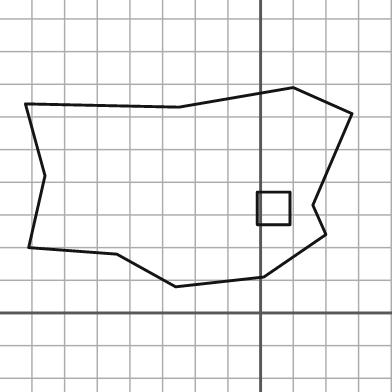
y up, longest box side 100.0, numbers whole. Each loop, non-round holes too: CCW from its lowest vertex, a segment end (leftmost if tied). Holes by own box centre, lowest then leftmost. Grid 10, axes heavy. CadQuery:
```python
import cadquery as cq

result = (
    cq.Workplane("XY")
    .moveTo(-26.0, 8.0)
    .lineTo(1.0, 11.0)
    .lineTo(20.0, 24.0)
    .lineTo(16.0, 33.0)
    .lineTo(28.0, 61.0)
    .lineTo(10.0, 69.0)
    .lineTo(-25.0, 63.0)
    .lineTo(-72.0, 64.0)
    .lineTo(-66.0, 42.0)
    .lineTo(-71.0, 20.0)
    .lineTo(-44.0, 18.0)
    .close()
    .moveTo(-1.0, 27.0)
    .lineTo(9.0, 27.0)
    .lineTo(9.0, 37.0)
    .lineTo(-1.0, 37.0)
    .close()
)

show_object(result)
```